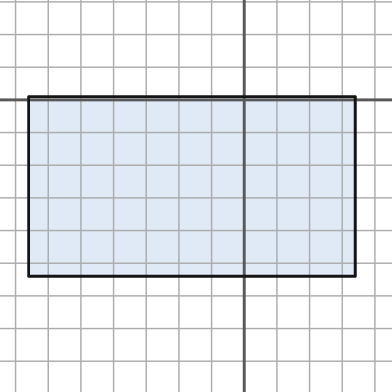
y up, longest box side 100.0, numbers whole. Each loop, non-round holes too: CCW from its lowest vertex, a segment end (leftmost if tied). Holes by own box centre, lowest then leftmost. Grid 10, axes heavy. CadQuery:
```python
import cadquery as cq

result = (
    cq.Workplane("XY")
    .moveTo(-66.0, -54.0)
    .lineTo(34.0, -54.0)
    .lineTo(34.0, 1.0)
    .lineTo(-66.0, 1.0)
    .close()
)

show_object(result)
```